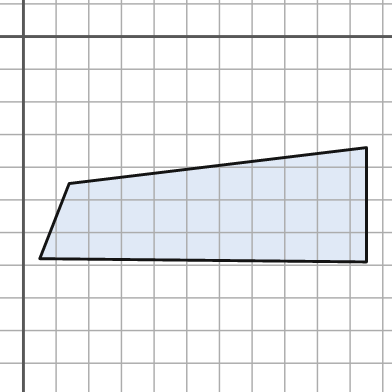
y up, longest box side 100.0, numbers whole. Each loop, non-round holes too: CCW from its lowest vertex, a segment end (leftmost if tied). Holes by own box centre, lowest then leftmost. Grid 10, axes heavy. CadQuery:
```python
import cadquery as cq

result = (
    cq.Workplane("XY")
    .moveTo(105.0, -69.0)
    .lineTo(105.0, -34.0)
    .lineTo(14.0, -45.0)
    .lineTo(5.0, -68.0)
    .close()
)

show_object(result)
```